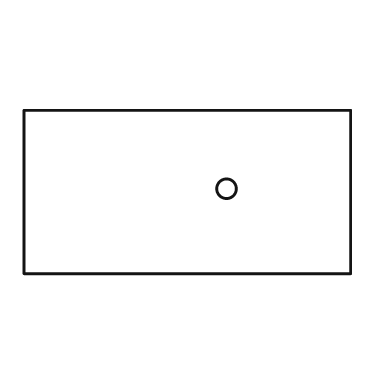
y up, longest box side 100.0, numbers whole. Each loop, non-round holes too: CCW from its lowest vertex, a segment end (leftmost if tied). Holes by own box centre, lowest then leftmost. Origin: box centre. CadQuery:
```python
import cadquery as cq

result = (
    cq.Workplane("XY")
    .moveTo(-50.0, -25.0)
    .lineTo(50.0, -25.0)
    .lineTo(50.0, 25.0)
    .lineTo(-50.0, 25.0)
    .close()
    .moveTo(12.0, 1.0)
    .circle(3.0)
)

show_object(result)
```